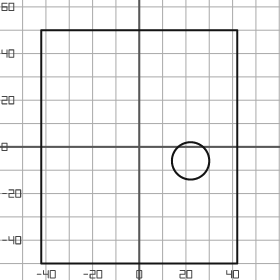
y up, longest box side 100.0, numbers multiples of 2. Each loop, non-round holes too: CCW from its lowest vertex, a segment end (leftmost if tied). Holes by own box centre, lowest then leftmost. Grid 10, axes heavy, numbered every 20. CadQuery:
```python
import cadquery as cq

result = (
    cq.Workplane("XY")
    .moveTo(-42.0, -50.0)
    .lineTo(42.0, -50.0)
    .lineTo(42.0, 50.0)
    .lineTo(-42.0, 50.0)
    .close()
    .moveTo(22.0, -6.0)
    .circle(8.0)
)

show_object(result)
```